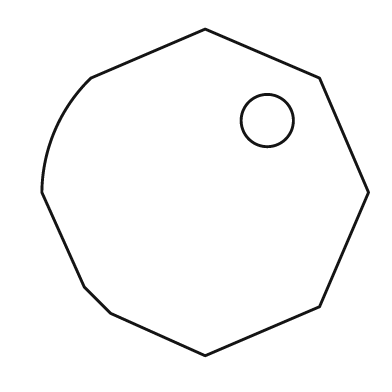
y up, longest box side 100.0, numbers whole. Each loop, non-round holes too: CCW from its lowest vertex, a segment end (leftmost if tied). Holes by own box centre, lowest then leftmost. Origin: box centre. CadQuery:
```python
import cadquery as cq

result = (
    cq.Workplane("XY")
    .moveTo(0.0, -50.0)
    .lineTo(35.0, -35.0)
    .lineTo(50.0, 0.0)
    .lineTo(35.0, 35.0)
    .lineTo(0.0, 50.0)
    .lineTo(-35.0, 35.0)
    .threePointArc((-46.0, 19.0), (-50.0, 0.0))
    .lineTo(-37.0, -29.0)
    .lineTo(-29.0, -37.0)
    .close()
    .moveTo(19.0, 22.0)
    .circle(8.0)
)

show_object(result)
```